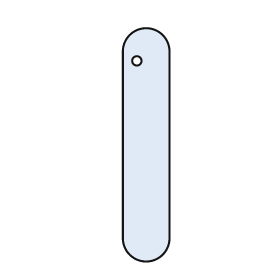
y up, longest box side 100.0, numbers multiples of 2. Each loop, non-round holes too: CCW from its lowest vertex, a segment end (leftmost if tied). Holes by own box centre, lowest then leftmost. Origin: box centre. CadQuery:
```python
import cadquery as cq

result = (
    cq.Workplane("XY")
    .moveTo(-10.0, -40.0)
    .threePointArc((0.0, -50.0), (10.0, -40.0))
    .lineTo(10.0, 40.0)
    .threePointArc((0.0, 50.0), (-10.0, 40.0))
    .close()
    .moveTo(-4.0, 36.0)
    .circle(2.0)
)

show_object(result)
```